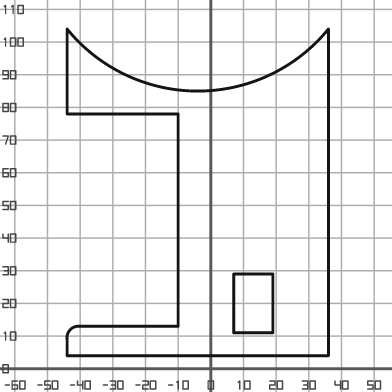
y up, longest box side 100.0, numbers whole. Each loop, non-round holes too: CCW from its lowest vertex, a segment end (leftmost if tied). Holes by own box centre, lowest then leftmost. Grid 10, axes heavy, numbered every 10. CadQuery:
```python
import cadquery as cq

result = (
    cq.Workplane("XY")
    .moveTo(-44.0, 4.0)
    .lineTo(36.0, 4.0)
    .lineTo(36.0, 104.0)
    .threePointArc((-4.0, 85.0), (-44.0, 104.0))
    .lineTo(-44.0, 78.0)
    .lineTo(-10.0, 78.0)
    .lineTo(-10.0, 13.0)
    .lineTo(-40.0, 13.0)
    .threePointArc((-43.0, 12.0), (-44.0, 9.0))
    .close()
    .moveTo(7.0, 11.0)
    .lineTo(19.0, 11.0)
    .lineTo(19.0, 29.0)
    .lineTo(7.0, 29.0)
    .close()
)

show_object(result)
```